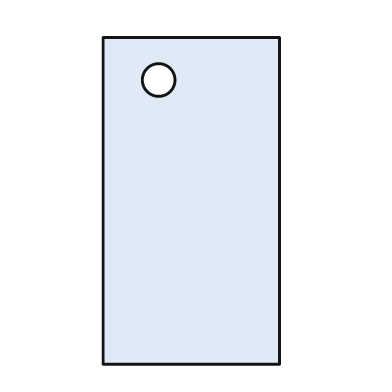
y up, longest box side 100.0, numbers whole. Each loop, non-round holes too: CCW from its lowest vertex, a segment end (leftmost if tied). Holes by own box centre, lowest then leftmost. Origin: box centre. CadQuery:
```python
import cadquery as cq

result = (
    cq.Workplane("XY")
    .moveTo(-27.0, -50.0)
    .lineTo(27.0, -50.0)
    .lineTo(27.0, 50.0)
    .lineTo(-27.0, 50.0)
    .close()
    .moveTo(-10.0, 37.0)
    .circle(5.0)
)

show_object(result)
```